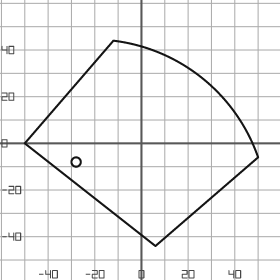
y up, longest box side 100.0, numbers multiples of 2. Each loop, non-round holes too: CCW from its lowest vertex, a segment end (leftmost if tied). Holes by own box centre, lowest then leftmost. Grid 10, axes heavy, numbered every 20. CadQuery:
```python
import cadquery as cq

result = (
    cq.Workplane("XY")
    .moveTo(6.0, -44.0)
    .lineTo(50.0, -6.0)
    .threePointArc((26.0, 28.0), (-12.0, 44.0))
    .lineTo(-50.0, 0.0)
    .close()
    .moveTo(-28.0, -8.0)
    .circle(2.0)
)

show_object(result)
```